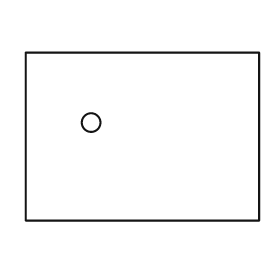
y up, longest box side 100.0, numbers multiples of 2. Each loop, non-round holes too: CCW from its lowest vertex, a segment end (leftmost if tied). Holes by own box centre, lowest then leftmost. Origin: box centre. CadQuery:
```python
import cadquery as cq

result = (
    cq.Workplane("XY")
    .moveTo(-50.0, -36.0)
    .lineTo(50.0, -36.0)
    .lineTo(50.0, 36.0)
    .lineTo(-50.0, 36.0)
    .close()
    .moveTo(-22.0, 6.0)
    .circle(4.0)
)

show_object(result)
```